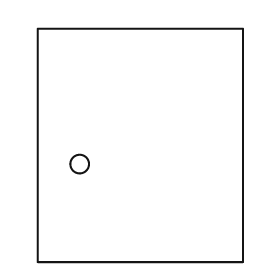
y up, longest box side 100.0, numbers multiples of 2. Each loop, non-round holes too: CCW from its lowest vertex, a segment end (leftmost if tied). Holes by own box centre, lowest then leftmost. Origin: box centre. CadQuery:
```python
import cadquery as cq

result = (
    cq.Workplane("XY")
    .moveTo(-44.0, -50.0)
    .lineTo(44.0, -50.0)
    .lineTo(44.0, 50.0)
    .lineTo(-44.0, 50.0)
    .close()
    .moveTo(-26.0, -8.0)
    .circle(4.0)
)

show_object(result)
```